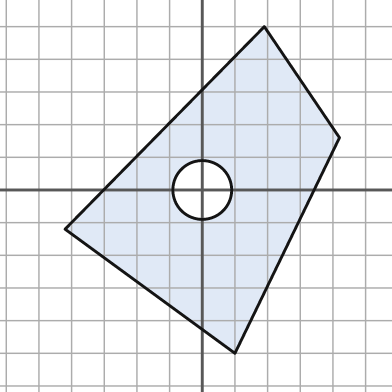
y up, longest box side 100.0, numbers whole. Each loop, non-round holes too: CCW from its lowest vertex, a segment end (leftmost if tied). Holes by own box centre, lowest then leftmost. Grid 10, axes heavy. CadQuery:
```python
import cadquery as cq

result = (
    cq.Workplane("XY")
    .moveTo(10.0, -50.0)
    .lineTo(42.0, 16.0)
    .lineTo(19.0, 50.0)
    .lineTo(-42.0, -12.0)
    .close()
    .moveTo(0.0, 0.0)
    .circle(9.0)
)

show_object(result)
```